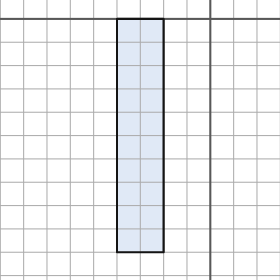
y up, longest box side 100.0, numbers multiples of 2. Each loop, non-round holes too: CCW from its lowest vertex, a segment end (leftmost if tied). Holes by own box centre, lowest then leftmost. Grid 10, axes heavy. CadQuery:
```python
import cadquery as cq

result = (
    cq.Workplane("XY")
    .moveTo(-40.0, -100.0)
    .lineTo(-20.0, -100.0)
    .lineTo(-20.0, 0.0)
    .lineTo(-40.0, 0.0)
    .close()
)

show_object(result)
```